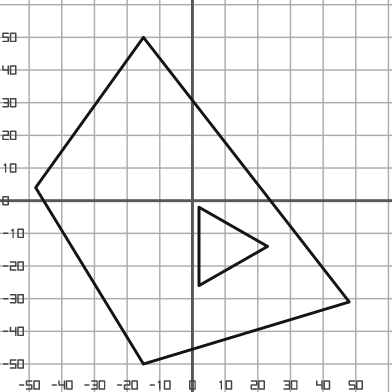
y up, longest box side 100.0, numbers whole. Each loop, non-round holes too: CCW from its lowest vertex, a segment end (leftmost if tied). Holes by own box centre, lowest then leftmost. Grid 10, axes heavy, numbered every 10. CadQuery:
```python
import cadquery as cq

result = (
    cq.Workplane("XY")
    .moveTo(-15.0, -50.0)
    .lineTo(48.0, -31.0)
    .lineTo(-15.0, 50.0)
    .lineTo(-48.0, 4.0)
    .close()
    .moveTo(2.0, -26.0)
    .lineTo(23.0, -14.0)
    .lineTo(2.0, -2.0)
    .close()
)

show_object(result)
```